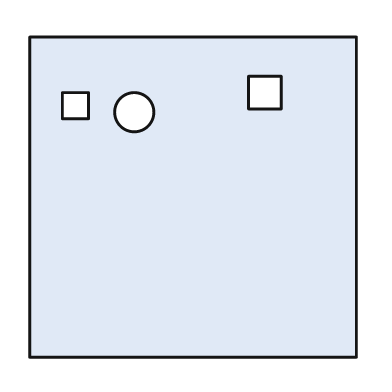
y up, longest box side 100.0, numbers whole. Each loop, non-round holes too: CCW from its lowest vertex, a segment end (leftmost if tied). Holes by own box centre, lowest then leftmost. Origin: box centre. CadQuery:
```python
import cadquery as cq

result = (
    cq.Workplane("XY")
    .moveTo(-50.0, -49.0)
    .lineTo(50.0, -49.0)
    .lineTo(50.0, 49.0)
    .lineTo(-50.0, 49.0)
    .close()
    .moveTo(-18.0, 26.0)
    .circle(6.0)
    .moveTo(-40.0, 24.0)
    .lineTo(-32.0, 24.0)
    .lineTo(-32.0, 32.0)
    .lineTo(-40.0, 32.0)
    .close()
    .moveTo(17.0, 27.0)
    .lineTo(27.0, 27.0)
    .lineTo(27.0, 37.0)
    .lineTo(17.0, 37.0)
    .close()
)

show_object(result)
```